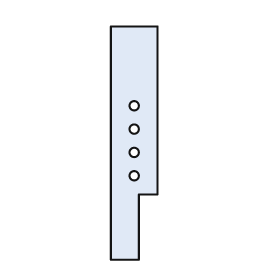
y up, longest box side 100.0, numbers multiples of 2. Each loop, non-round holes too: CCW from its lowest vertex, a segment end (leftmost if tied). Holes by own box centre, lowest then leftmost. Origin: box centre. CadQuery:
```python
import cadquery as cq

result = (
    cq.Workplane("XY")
    .moveTo(-10.0, -50.0)
    .lineTo(2.0, -50.0)
    .lineTo(2.0, -22.0)
    .lineTo(10.0, -22.0)
    .lineTo(10.0, 50.0)
    .lineTo(-10.0, 50.0)
    .close()
    .moveTo(0.0, -14.0)
    .circle(2.0)
    .moveTo(0.0, -4.0)
    .circle(2.0)
    .moveTo(0.0, 6.0)
    .circle(2.0)
    .moveTo(0.0, 16.0)
    .circle(2.0)
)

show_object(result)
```